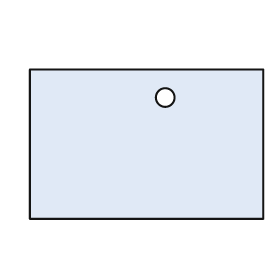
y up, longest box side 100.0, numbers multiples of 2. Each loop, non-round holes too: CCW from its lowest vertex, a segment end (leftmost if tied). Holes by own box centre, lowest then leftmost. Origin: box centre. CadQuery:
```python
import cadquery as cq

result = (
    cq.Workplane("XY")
    .moveTo(-50.0, -32.0)
    .lineTo(50.0, -32.0)
    .lineTo(50.0, 32.0)
    .lineTo(-50.0, 32.0)
    .close()
    .moveTo(8.0, 20.0)
    .circle(4.0)
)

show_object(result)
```